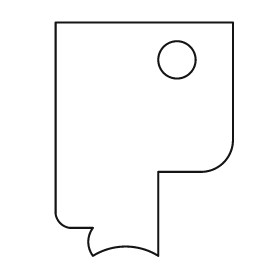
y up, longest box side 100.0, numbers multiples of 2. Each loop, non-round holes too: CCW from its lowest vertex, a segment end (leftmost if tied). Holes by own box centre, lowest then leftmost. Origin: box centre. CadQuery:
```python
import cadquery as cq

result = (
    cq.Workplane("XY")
    .moveTo(-22.0, -50.0)
    .threePointArc((-8.0, -46.0), (6.0, -50.0))
    .lineTo(6.0, -14.0)
    .lineTo(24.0, -14.0)
    .threePointArc((34.0, -10.0), (38.0, 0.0))
    .lineTo(38.0, 50.0)
    .lineTo(-38.0, 50.0)
    .lineTo(-38.0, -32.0)
    .threePointArc((-36.0, -36.0), (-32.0, -38.0))
    .lineTo(-22.0, -38.0)
    .threePointArc((-24.0, -44.0), (-22.0, -50.0))
    .close()
    .moveTo(14.0, 34.0)
    .circle(8.0)
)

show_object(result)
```